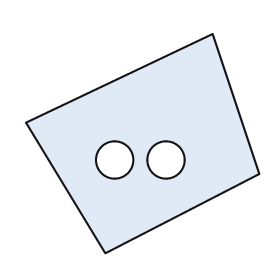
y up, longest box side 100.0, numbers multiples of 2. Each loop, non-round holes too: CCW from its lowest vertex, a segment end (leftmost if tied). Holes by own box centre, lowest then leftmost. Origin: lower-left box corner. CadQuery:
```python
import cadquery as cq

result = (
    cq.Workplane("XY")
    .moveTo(34.0, 0.0)
    .lineTo(100.0, 34.0)
    .lineTo(80.0, 94.0)
    .lineTo(0.0, 56.0)
    .close()
    .moveTo(38.0, 40.0)
    .circle(8.0)
    .moveTo(60.0, 40.0)
    .circle(8.0)
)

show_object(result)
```